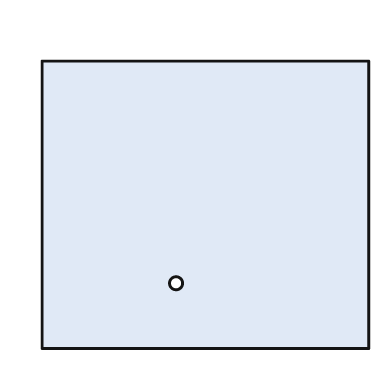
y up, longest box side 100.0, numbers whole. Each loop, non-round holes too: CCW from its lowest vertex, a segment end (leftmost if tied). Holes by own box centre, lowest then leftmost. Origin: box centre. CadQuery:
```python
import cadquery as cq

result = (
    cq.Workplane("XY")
    .moveTo(-50.0, -44.0)
    .lineTo(50.0, -44.0)
    .lineTo(50.0, 44.0)
    .lineTo(-50.0, 44.0)
    .close()
    .moveTo(-9.0, -24.0)
    .circle(2.0)
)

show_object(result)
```